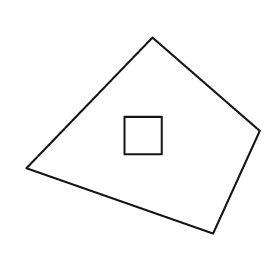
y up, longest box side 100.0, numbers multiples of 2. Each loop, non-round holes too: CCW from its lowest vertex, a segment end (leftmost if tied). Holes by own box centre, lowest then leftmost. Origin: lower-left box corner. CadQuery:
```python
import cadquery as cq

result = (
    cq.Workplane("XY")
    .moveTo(80.0, 0.0)
    .lineTo(100.0, 44.0)
    .lineTo(54.0, 84.0)
    .lineTo(0.0, 28.0)
    .close()
    .moveTo(42.0, 34.0)
    .lineTo(58.0, 34.0)
    .lineTo(58.0, 50.0)
    .lineTo(42.0, 50.0)
    .close()
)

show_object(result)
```